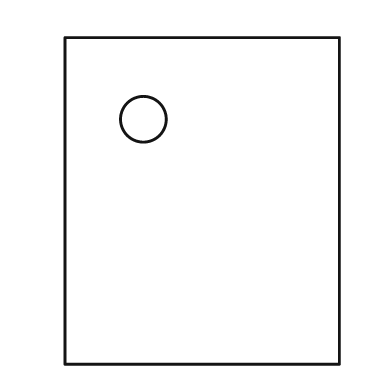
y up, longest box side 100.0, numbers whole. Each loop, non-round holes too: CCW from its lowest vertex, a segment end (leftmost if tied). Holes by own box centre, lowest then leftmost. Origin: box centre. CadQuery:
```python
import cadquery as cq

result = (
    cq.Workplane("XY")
    .moveTo(-42.0, -50.0)
    .lineTo(42.0, -50.0)
    .lineTo(42.0, 50.0)
    .lineTo(-42.0, 50.0)
    .close()
    .moveTo(-18.0, 25.0)
    .circle(7.0)
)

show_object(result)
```